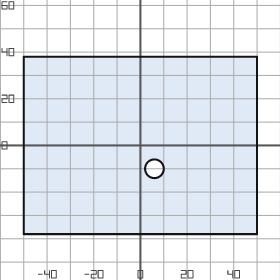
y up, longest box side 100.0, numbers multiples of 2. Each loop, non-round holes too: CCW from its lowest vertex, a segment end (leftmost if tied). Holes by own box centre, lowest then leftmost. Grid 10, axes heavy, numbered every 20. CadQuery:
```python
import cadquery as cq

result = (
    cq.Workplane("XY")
    .moveTo(-50.0, -38.0)
    .lineTo(50.0, -38.0)
    .lineTo(50.0, 38.0)
    .lineTo(-50.0, 38.0)
    .close()
    .moveTo(6.0, -10.0)
    .circle(4.0)
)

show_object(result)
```